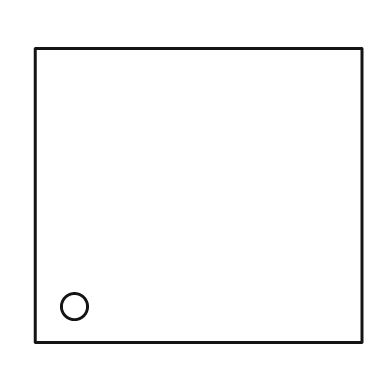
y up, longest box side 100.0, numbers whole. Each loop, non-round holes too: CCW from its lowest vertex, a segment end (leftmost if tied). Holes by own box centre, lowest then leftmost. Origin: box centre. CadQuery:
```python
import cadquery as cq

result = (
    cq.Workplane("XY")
    .moveTo(-50.0, -45.0)
    .lineTo(50.0, -45.0)
    .lineTo(50.0, 45.0)
    .lineTo(-50.0, 45.0)
    .close()
    .moveTo(-38.0, -34.0)
    .circle(4.0)
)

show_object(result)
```